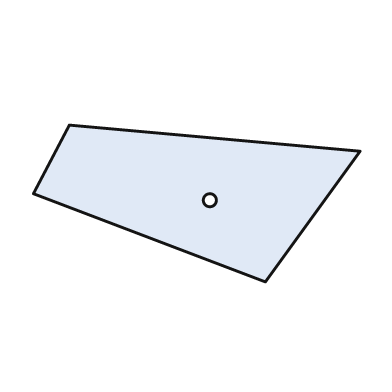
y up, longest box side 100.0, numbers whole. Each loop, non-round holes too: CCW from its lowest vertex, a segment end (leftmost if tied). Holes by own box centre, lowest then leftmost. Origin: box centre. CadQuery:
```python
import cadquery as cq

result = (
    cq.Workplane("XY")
    .moveTo(21.0, -24.0)
    .lineTo(50.0, 16.0)
    .lineTo(-39.0, 24.0)
    .lineTo(-50.0, 3.0)
    .close()
    .moveTo(4.0, 1.0)
    .circle(2.0)
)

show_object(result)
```